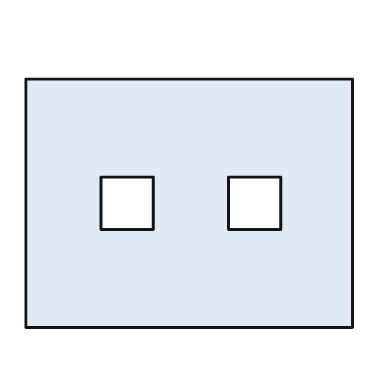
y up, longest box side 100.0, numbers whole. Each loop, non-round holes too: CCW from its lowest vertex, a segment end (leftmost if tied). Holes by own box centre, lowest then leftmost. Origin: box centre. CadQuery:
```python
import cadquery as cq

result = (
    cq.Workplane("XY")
    .moveTo(-50.0, -38.0)
    .lineTo(50.0, -38.0)
    .lineTo(50.0, 38.0)
    .lineTo(-50.0, 38.0)
    .close()
    .moveTo(-27.0, -8.0)
    .lineTo(-11.0, -8.0)
    .lineTo(-11.0, 8.0)
    .lineTo(-27.0, 8.0)
    .close()
    .moveTo(12.0, -8.0)
    .lineTo(28.0, -8.0)
    .lineTo(28.0, 8.0)
    .lineTo(12.0, 8.0)
    .close()
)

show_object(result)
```